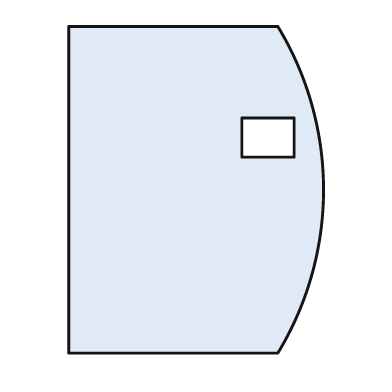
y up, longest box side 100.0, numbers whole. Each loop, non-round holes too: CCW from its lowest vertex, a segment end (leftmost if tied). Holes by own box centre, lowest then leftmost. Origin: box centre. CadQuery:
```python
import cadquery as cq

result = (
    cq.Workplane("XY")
    .moveTo(-39.0, -50.0)
    .lineTo(25.0, -50.0)
    .threePointArc((39.0, 0.0), (25.0, 50.0))
    .lineTo(-39.0, 50.0)
    .close()
    .moveTo(14.0, 10.0)
    .lineTo(30.0, 10.0)
    .lineTo(30.0, 22.0)
    .lineTo(14.0, 22.0)
    .close()
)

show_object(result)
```